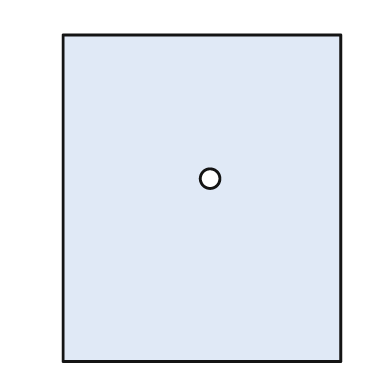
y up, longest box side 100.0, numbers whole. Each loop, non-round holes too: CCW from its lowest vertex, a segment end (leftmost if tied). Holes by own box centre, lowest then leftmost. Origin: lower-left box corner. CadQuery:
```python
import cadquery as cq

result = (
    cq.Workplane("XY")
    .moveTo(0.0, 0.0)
    .lineTo(85.0, 0.0)
    .lineTo(85.0, 100.0)
    .lineTo(0.0, 100.0)
    .close()
    .moveTo(45.0, 56.0)
    .circle(3.0)
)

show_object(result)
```